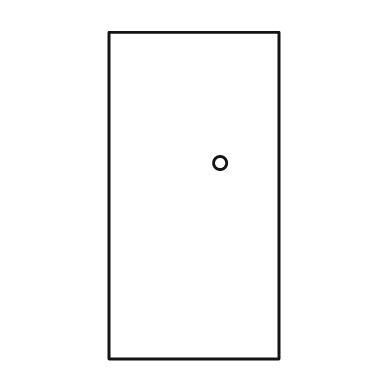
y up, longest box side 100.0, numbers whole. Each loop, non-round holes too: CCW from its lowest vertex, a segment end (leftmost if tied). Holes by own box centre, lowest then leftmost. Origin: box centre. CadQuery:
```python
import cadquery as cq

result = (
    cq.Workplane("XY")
    .moveTo(-26.0, -50.0)
    .lineTo(26.0, -50.0)
    .lineTo(26.0, 50.0)
    .lineTo(-26.0, 50.0)
    .close()
    .moveTo(8.0, 10.0)
    .circle(2.0)
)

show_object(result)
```